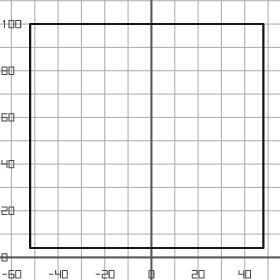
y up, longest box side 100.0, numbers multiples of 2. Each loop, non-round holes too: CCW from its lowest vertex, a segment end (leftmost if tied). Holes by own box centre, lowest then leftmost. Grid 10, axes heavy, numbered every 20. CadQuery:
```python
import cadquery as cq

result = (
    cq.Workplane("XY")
    .moveTo(-52.0, 4.0)
    .lineTo(48.0, 4.0)
    .lineTo(48.0, 100.0)
    .lineTo(-52.0, 100.0)
    .close()
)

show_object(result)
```